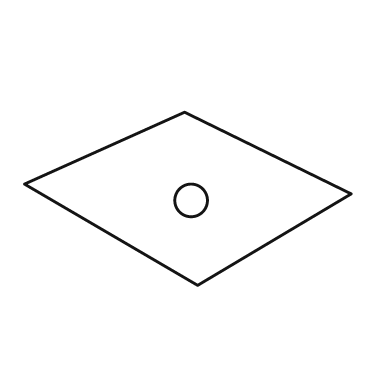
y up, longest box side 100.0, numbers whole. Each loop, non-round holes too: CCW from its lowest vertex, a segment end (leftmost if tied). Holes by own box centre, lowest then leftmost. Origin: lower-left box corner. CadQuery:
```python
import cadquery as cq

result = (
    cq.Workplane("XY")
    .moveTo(53.0, 0.0)
    .lineTo(100.0, 28.0)
    .lineTo(49.0, 53.0)
    .lineTo(0.0, 31.0)
    .close()
    .moveTo(51.0, 26.0)
    .circle(5.0)
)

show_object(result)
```